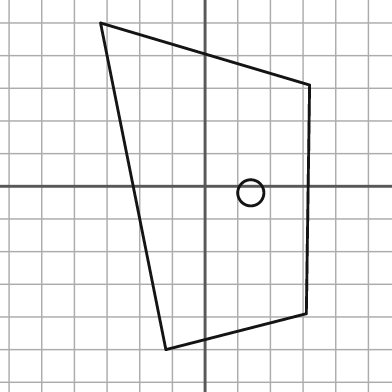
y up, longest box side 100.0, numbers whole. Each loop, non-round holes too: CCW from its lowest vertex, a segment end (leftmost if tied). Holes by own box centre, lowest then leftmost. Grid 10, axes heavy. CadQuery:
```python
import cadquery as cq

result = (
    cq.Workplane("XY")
    .moveTo(-12.0, -50.0)
    .lineTo(31.0, -39.0)
    .lineTo(32.0, 31.0)
    .lineTo(-32.0, 50.0)
    .close()
    .moveTo(14.0, -2.0)
    .circle(4.0)
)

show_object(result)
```